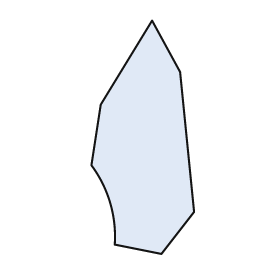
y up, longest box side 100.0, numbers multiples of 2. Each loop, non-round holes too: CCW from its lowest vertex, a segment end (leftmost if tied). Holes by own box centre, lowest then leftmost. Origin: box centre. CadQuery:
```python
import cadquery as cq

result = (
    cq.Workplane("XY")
    .moveTo(8.0, -50.0)
    .lineTo(22.0, -32.0)
    .lineTo(16.0, 28.0)
    .lineTo(4.0, 50.0)
    .lineTo(-18.0, 14.0)
    .lineTo(-22.0, -12.0)
    .threePointArc((-14.0, -28.0), (-12.0, -46.0))
    .close()
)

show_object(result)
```